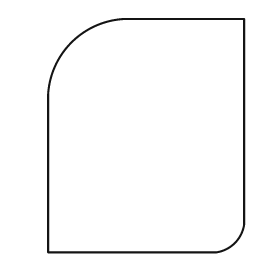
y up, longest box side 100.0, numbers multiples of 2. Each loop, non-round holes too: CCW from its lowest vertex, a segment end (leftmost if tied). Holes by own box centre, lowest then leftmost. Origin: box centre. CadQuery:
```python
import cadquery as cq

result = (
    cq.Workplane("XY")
    .moveTo(-42.0, -50.0)
    .lineTo(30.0, -50.0)
    .threePointArc((38.0, -46.0), (42.0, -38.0))
    .lineTo(42.0, 50.0)
    .lineTo(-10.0, 50.0)
    .threePointArc((-32.0, 40.0), (-42.0, 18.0))
    .close()
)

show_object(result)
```